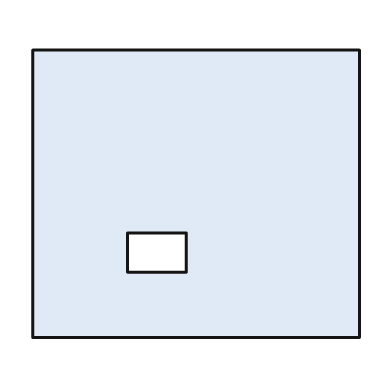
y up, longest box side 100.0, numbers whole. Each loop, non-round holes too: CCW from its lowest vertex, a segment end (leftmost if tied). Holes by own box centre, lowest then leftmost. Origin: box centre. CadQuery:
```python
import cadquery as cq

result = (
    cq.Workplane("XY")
    .moveTo(-50.0, -44.0)
    .lineTo(50.0, -44.0)
    .lineTo(50.0, 44.0)
    .lineTo(-50.0, 44.0)
    .close()
    .moveTo(-21.0, -24.0)
    .lineTo(-3.0, -24.0)
    .lineTo(-3.0, -12.0)
    .lineTo(-21.0, -12.0)
    .close()
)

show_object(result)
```